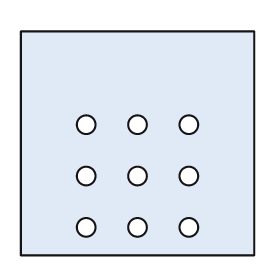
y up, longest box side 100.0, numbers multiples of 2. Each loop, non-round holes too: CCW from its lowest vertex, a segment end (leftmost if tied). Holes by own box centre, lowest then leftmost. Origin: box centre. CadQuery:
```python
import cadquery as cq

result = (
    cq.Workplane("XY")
    .moveTo(-50.0, -48.0)
    .lineTo(50.0, -48.0)
    .lineTo(50.0, 48.0)
    .lineTo(-50.0, 48.0)
    .close()
    .moveTo(-22.0, -36.0)
    .circle(4.0)
    .moveTo(0.0, -36.0)
    .circle(4.0)
    .moveTo(22.0, -36.0)
    .circle(4.0)
    .moveTo(-22.0, -14.0)
    .circle(4.0)
    .moveTo(0.0, -14.0)
    .circle(4.0)
    .moveTo(22.0, -14.0)
    .circle(4.0)
    .moveTo(-22.0, 8.0)
    .circle(4.0)
    .moveTo(0.0, 8.0)
    .circle(4.0)
    .moveTo(22.0, 8.0)
    .circle(4.0)
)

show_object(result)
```